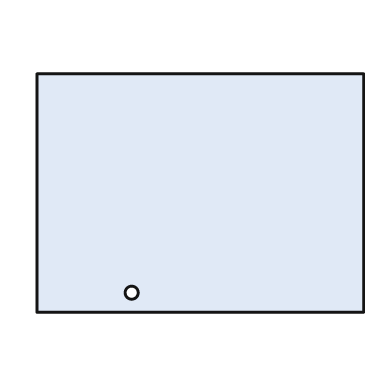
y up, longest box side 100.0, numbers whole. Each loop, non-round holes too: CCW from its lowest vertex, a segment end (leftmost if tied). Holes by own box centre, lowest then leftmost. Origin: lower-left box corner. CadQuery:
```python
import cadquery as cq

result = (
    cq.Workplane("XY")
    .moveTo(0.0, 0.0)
    .lineTo(100.0, 0.0)
    .lineTo(100.0, 73.0)
    .lineTo(0.0, 73.0)
    .close()
    .moveTo(29.0, 6.0)
    .circle(2.0)
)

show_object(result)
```